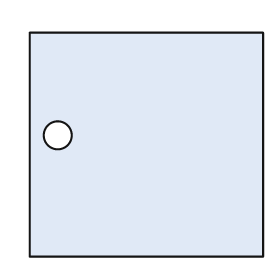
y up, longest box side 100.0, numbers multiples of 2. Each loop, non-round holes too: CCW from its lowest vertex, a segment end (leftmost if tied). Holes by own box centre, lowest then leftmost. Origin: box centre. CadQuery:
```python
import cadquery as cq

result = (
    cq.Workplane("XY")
    .moveTo(-50.0, -48.0)
    .lineTo(50.0, -48.0)
    .lineTo(50.0, 48.0)
    .lineTo(-50.0, 48.0)
    .close()
    .moveTo(-38.0, 4.0)
    .circle(6.0)
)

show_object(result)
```